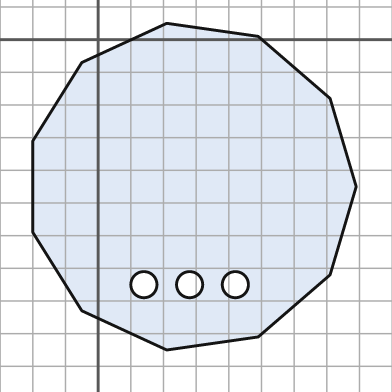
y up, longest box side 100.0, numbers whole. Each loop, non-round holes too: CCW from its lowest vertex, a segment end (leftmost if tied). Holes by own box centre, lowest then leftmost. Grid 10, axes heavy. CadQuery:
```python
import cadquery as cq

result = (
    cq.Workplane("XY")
    .moveTo(21.0, -95.0)
    .lineTo(49.0, -91.0)
    .lineTo(71.0, -72.0)
    .lineTo(79.0, -45.0)
    .lineTo(71.0, -18.0)
    .lineTo(49.0, 1.0)
    .lineTo(21.0, 5.0)
    .lineTo(-5.0, -7.0)
    .lineTo(-20.0, -31.0)
    .lineTo(-20.0, -59.0)
    .lineTo(-5.0, -83.0)
    .close()
    .moveTo(14.0, -75.0)
    .circle(4.0)
    .moveTo(28.0, -75.0)
    .circle(4.0)
    .moveTo(42.0, -75.0)
    .circle(4.0)
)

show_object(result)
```